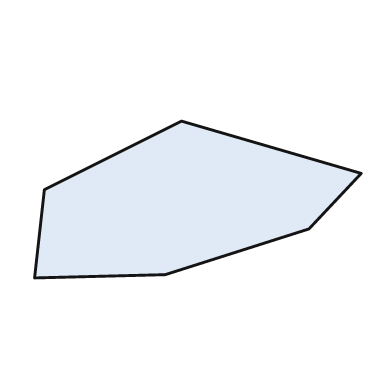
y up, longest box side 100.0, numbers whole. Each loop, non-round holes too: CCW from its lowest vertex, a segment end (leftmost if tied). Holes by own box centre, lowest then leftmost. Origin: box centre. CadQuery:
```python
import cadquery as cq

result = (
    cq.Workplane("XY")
    .moveTo(-50.0, -24.0)
    .lineTo(-10.0, -23.0)
    .lineTo(34.0, -9.0)
    .lineTo(50.0, 8.0)
    .lineTo(-5.0, 24.0)
    .lineTo(-47.0, 3.0)
    .close()
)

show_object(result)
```